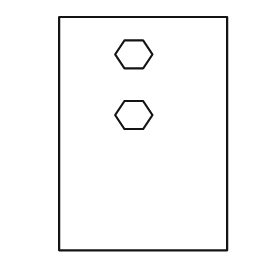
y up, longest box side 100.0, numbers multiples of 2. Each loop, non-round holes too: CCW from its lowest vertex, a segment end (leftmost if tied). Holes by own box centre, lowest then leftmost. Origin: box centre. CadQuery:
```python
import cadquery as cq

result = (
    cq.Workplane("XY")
    .moveTo(-36.0, -50.0)
    .lineTo(36.0, -50.0)
    .lineTo(36.0, 50.0)
    .lineTo(-36.0, 50.0)
    .close()
    .moveTo(-8.0, 2.0)
    .lineTo(0.0, 2.0)
    .lineTo(4.0, 8.0)
    .lineTo(0.0, 14.0)
    .lineTo(-8.0, 14.0)
    .lineTo(-12.0, 8.0)
    .close()
    .moveTo(-8.0, 28.0)
    .lineTo(0.0, 28.0)
    .lineTo(4.0, 34.0)
    .lineTo(0.0, 40.0)
    .lineTo(-8.0, 40.0)
    .lineTo(-12.0, 34.0)
    .close()
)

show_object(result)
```